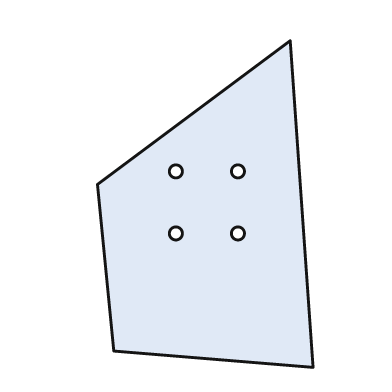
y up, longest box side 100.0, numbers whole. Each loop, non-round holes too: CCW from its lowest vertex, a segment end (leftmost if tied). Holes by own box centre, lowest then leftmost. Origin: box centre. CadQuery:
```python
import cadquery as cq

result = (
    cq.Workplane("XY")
    .moveTo(33.0, -50.0)
    .lineTo(26.0, 50.0)
    .lineTo(-33.0, 6.0)
    .lineTo(-28.0, -45.0)
    .close()
    .moveTo(-9.0, -9.0)
    .circle(2.0)
    .moveTo(10.0, -9.0)
    .circle(2.0)
    .moveTo(-9.0, 10.0)
    .circle(2.0)
    .moveTo(10.0, 10.0)
    .circle(2.0)
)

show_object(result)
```